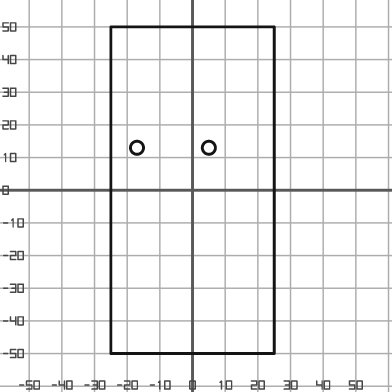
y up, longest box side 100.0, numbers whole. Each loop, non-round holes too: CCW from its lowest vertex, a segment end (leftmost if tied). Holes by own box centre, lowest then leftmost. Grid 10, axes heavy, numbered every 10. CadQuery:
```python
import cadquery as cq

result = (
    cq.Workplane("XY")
    .moveTo(-25.0, -50.0)
    .lineTo(25.0, -50.0)
    .lineTo(25.0, 50.0)
    .lineTo(-25.0, 50.0)
    .close()
    .moveTo(-17.0, 13.0)
    .circle(2.0)
    .moveTo(5.0, 13.0)
    .circle(2.0)
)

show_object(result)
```